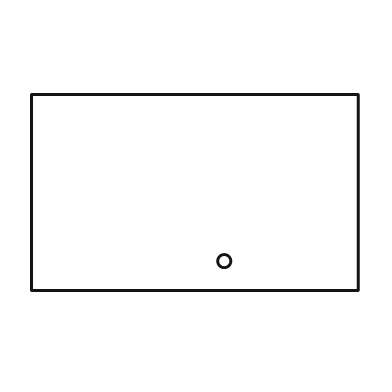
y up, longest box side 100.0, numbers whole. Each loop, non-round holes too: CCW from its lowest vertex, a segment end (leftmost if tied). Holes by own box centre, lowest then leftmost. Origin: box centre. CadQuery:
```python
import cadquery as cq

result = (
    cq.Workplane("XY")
    .moveTo(-50.0, -30.0)
    .lineTo(50.0, -30.0)
    .lineTo(50.0, 30.0)
    .lineTo(-50.0, 30.0)
    .close()
    .moveTo(9.0, -21.0)
    .circle(2.0)
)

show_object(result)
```